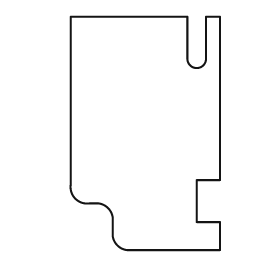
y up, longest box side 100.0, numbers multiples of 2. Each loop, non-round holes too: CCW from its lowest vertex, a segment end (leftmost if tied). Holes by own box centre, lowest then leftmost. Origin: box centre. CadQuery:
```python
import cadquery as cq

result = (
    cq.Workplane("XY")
    .moveTo(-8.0, -50.0)
    .lineTo(32.0, -50.0)
    .lineTo(32.0, -38.0)
    .lineTo(22.0, -38.0)
    .lineTo(22.0, -20.0)
    .lineTo(32.0, -20.0)
    .lineTo(32.0, 50.0)
    .lineTo(26.0, 50.0)
    .lineTo(26.0, 32.0)
    .threePointArc((22.0, 28.0), (18.0, 32.0))
    .lineTo(18.0, 50.0)
    .lineTo(-32.0, 50.0)
    .lineTo(-32.0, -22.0)
    .threePointArc((-30.0, -28.0), (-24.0, -30.0))
    .lineTo(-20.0, -30.0)
    .threePointArc((-16.0, -32.0), (-14.0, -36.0))
    .lineTo(-14.0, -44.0)
    .threePointArc((-12.0, -48.0), (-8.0, -50.0))
    .close()
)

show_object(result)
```